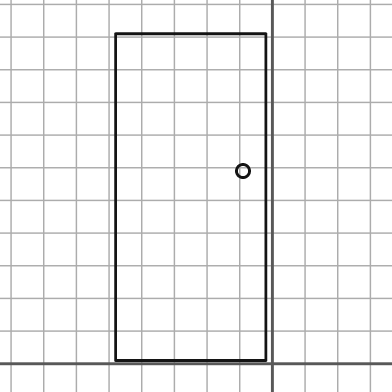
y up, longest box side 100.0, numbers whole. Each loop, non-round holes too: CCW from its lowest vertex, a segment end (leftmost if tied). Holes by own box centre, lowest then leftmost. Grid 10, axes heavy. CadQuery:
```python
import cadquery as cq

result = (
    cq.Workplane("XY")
    .moveTo(-48.0, 1.0)
    .lineTo(-2.0, 1.0)
    .lineTo(-2.0, 101.0)
    .lineTo(-48.0, 101.0)
    .close()
    .moveTo(-9.0, 59.0)
    .circle(2.0)
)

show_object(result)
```